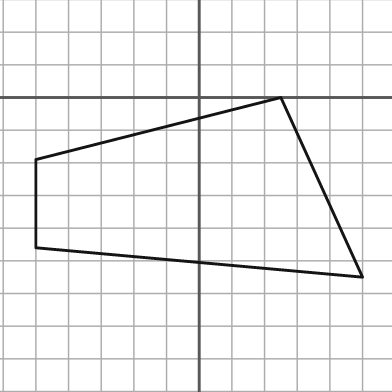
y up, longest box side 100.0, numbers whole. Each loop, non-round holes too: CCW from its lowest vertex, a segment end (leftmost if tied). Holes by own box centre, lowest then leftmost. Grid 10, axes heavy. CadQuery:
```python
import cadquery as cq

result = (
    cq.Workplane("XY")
    .moveTo(50.0, -55.0)
    .lineTo(25.0, 0.0)
    .lineTo(-50.0, -19.0)
    .lineTo(-50.0, -46.0)
    .close()
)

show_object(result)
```